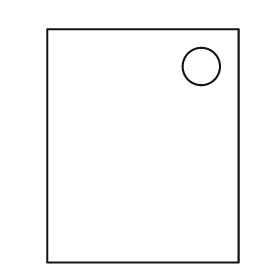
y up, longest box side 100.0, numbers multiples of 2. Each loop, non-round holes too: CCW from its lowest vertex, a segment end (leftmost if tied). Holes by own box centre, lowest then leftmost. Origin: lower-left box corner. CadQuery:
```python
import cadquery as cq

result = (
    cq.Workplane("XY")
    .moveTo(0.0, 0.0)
    .lineTo(82.0, 0.0)
    .lineTo(82.0, 100.0)
    .lineTo(0.0, 100.0)
    .close()
    .moveTo(66.0, 84.0)
    .circle(8.0)
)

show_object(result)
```